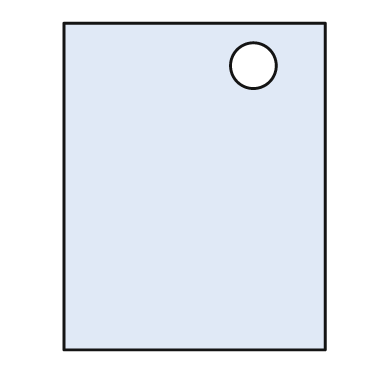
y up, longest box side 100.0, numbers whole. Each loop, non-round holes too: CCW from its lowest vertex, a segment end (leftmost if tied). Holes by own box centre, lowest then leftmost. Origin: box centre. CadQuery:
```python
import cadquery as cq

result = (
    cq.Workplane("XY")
    .moveTo(-40.0, -50.0)
    .lineTo(40.0, -50.0)
    .lineTo(40.0, 50.0)
    .lineTo(-40.0, 50.0)
    .close()
    .moveTo(18.0, 37.0)
    .circle(7.0)
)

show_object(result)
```